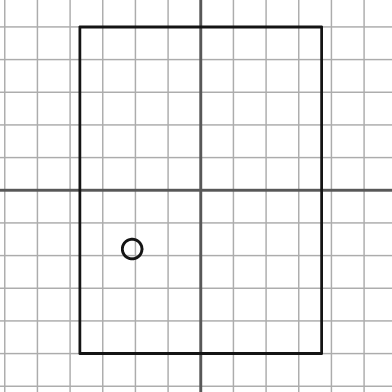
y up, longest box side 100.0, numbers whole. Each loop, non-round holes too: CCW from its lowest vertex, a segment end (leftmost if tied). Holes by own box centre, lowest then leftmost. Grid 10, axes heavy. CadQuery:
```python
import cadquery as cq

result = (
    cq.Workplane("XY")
    .moveTo(-37.0, -50.0)
    .lineTo(37.0, -50.0)
    .lineTo(37.0, 50.0)
    .lineTo(-37.0, 50.0)
    .close()
    .moveTo(-21.0, -18.0)
    .circle(3.0)
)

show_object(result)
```